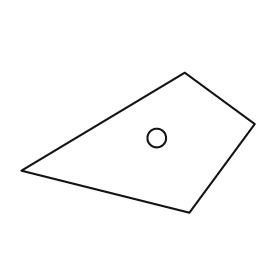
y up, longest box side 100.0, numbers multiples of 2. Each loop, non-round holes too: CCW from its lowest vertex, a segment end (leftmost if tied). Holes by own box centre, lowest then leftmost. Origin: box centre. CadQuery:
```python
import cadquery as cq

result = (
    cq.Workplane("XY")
    .moveTo(22.0, -30.0)
    .lineTo(50.0, 8.0)
    .lineTo(20.0, 30.0)
    .lineTo(-50.0, -12.0)
    .close()
    .moveTo(8.0, 2.0)
    .circle(4.0)
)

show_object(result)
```